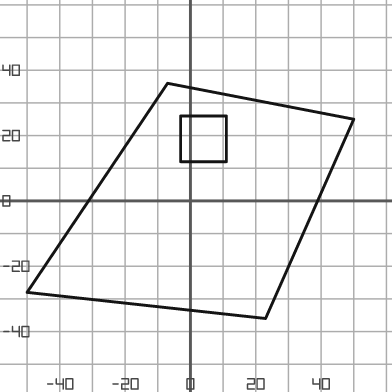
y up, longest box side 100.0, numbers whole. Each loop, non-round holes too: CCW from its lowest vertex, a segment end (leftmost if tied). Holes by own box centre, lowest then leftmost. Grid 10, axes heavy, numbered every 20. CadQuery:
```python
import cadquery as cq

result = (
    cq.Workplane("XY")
    .moveTo(23.0, -36.0)
    .lineTo(50.0, 25.0)
    .lineTo(-7.0, 36.0)
    .lineTo(-50.0, -28.0)
    .close()
    .moveTo(-3.0, 12.0)
    .lineTo(11.0, 12.0)
    .lineTo(11.0, 26.0)
    .lineTo(-3.0, 26.0)
    .close()
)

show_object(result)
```